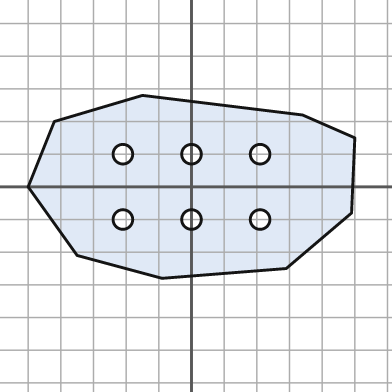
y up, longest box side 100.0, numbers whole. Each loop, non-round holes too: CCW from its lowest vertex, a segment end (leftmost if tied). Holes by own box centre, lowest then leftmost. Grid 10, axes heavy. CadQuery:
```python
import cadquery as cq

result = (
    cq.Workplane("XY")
    .moveTo(-9.0, -28.0)
    .lineTo(29.0, -25.0)
    .lineTo(49.0, -8.0)
    .lineTo(50.0, 15.0)
    .lineTo(34.0, 22.0)
    .lineTo(-15.0, 28.0)
    .lineTo(-42.0, 20.0)
    .lineTo(-50.0, 0.0)
    .lineTo(-35.0, -21.0)
    .close()
    .moveTo(-21.0, -10.0)
    .circle(3.0)
    .moveTo(0.0, -10.0)
    .circle(3.0)
    .moveTo(21.0, -10.0)
    .circle(3.0)
    .moveTo(-21.0, 10.0)
    .circle(3.0)
    .moveTo(0.0, 10.0)
    .circle(3.0)
    .moveTo(21.0, 10.0)
    .circle(3.0)
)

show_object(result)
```